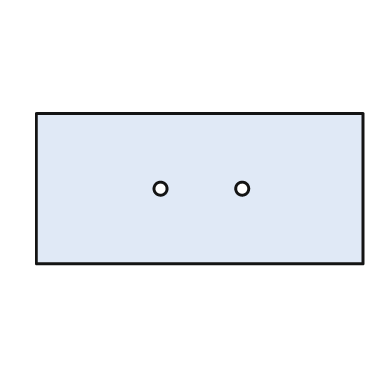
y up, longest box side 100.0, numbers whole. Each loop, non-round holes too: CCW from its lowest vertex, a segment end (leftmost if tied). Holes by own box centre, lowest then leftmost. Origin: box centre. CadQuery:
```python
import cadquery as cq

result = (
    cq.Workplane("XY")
    .moveTo(-50.0, -23.0)
    .lineTo(50.0, -23.0)
    .lineTo(50.0, 23.0)
    .lineTo(-50.0, 23.0)
    .close()
    .moveTo(-12.0, 0.0)
    .circle(2.0)
    .moveTo(13.0, 0.0)
    .circle(2.0)
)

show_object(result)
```